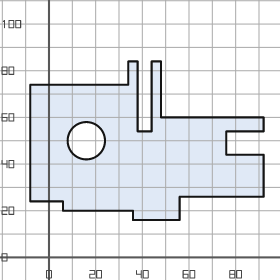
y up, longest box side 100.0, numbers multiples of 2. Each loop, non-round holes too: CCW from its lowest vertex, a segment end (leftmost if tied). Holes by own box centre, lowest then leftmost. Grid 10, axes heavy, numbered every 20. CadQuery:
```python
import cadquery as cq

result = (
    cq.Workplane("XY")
    .moveTo(36.0, 16.0)
    .lineTo(56.0, 16.0)
    .lineTo(56.0, 26.0)
    .lineTo(92.0, 26.0)
    .lineTo(92.0, 44.0)
    .lineTo(76.0, 44.0)
    .lineTo(76.0, 54.0)
    .lineTo(92.0, 54.0)
    .lineTo(92.0, 60.0)
    .lineTo(48.0, 60.0)
    .lineTo(48.0, 84.0)
    .lineTo(44.0, 84.0)
    .lineTo(44.0, 54.0)
    .lineTo(38.0, 54.0)
    .lineTo(38.0, 84.0)
    .lineTo(34.0, 84.0)
    .lineTo(34.0, 74.0)
    .lineTo(-8.0, 74.0)
    .lineTo(-8.0, 24.0)
    .lineTo(6.0, 24.0)
    .lineTo(6.0, 20.0)
    .lineTo(36.0, 20.0)
    .close()
    .moveTo(16.0, 50.0)
    .circle(8.0)
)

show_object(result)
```